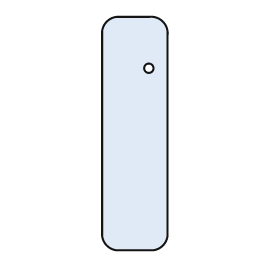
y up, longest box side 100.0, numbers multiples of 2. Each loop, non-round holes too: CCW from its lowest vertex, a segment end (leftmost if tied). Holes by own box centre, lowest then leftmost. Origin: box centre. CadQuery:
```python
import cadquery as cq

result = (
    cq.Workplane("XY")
    .moveTo(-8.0, -50.0)
    .lineTo(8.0, -50.0)
    .threePointArc((12.0, -48.0), (14.0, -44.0))
    .lineTo(14.0, 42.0)
    .threePointArc((12.0, 48.0), (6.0, 50.0))
    .lineTo(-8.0, 50.0)
    .threePointArc((-12.0, 48.0), (-14.0, 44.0))
    .lineTo(-14.0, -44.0)
    .threePointArc((-12.0, -48.0), (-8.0, -50.0))
    .close()
    .moveTo(6.0, 28.0)
    .circle(2.0)
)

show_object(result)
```